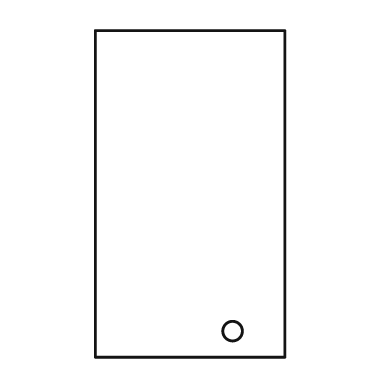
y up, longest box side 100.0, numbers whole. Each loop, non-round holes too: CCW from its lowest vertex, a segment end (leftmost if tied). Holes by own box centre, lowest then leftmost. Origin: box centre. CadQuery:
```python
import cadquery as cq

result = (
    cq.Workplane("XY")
    .moveTo(-29.0, -50.0)
    .lineTo(29.0, -50.0)
    .lineTo(29.0, 50.0)
    .lineTo(-29.0, 50.0)
    .close()
    .moveTo(13.0, -42.0)
    .circle(3.0)
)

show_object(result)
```